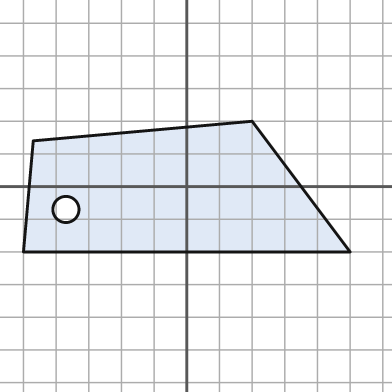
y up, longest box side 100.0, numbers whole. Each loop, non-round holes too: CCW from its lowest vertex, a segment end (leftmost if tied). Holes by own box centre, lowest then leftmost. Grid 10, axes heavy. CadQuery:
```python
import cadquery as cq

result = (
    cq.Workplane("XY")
    .moveTo(-50.0, -20.0)
    .lineTo(50.0, -20.0)
    .lineTo(20.0, 20.0)
    .lineTo(-47.0, 14.0)
    .close()
    .moveTo(-37.0, -7.0)
    .circle(4.0)
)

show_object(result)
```